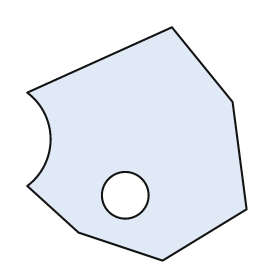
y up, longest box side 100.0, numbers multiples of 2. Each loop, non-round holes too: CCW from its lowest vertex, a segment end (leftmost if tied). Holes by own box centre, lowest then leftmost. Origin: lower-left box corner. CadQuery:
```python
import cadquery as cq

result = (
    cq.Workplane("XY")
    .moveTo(58.0, 0.0)
    .lineTo(94.0, 22.0)
    .lineTo(88.0, 68.0)
    .lineTo(62.0, 100.0)
    .lineTo(0.0, 72.0)
    .threePointArc((10.0, 52.0), (0.0, 32.0))
    .lineTo(22.0, 12.0)
    .close()
    .moveTo(42.0, 28.0)
    .circle(10.0)
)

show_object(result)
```